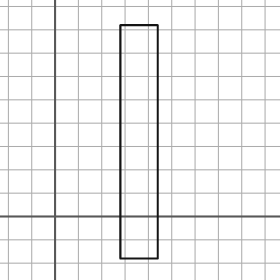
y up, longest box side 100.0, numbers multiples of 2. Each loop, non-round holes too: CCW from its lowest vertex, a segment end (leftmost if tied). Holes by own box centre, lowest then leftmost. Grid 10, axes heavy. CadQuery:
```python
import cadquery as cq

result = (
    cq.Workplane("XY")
    .moveTo(28.0, -18.0)
    .lineTo(44.0, -18.0)
    .lineTo(44.0, 82.0)
    .lineTo(28.0, 82.0)
    .close()
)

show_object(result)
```